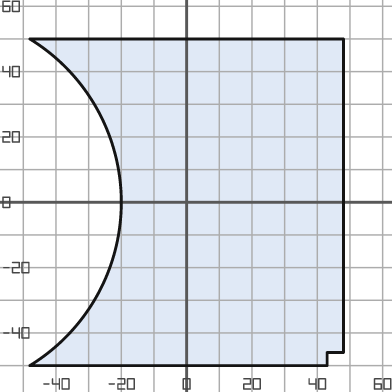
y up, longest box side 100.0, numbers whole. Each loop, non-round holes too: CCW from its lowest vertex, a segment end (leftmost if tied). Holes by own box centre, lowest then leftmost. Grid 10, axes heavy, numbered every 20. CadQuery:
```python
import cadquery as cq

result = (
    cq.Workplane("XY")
    .moveTo(-48.0, -50.0)
    .lineTo(43.0, -50.0)
    .lineTo(43.0, -46.0)
    .lineTo(48.0, -46.0)
    .lineTo(48.0, 50.0)
    .lineTo(-48.0, 50.0)
    .threePointArc((-20.0, 0.0), (-48.0, -50.0))
    .close()
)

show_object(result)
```